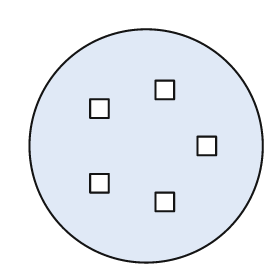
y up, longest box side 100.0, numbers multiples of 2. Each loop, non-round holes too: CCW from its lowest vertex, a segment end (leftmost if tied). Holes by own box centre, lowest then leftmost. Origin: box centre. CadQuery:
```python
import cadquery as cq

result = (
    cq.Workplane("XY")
    .moveTo(0.0, 0.0)
    .circle(50.0)
    .moveTo(4.0, -28.0)
    .lineTo(12.0, -28.0)
    .lineTo(12.0, -20.0)
    .lineTo(4.0, -20.0)
    .close()
    .moveTo(-24.0, -20.0)
    .lineTo(-16.0, -20.0)
    .lineTo(-16.0, -12.0)
    .lineTo(-24.0, -12.0)
    .close()
    .moveTo(22.0, -4.0)
    .lineTo(30.0, -4.0)
    .lineTo(30.0, 4.0)
    .lineTo(22.0, 4.0)
    .close()
    .moveTo(-24.0, 12.0)
    .lineTo(-16.0, 12.0)
    .lineTo(-16.0, 20.0)
    .lineTo(-24.0, 20.0)
    .close()
    .moveTo(4.0, 20.0)
    .lineTo(12.0, 20.0)
    .lineTo(12.0, 28.0)
    .lineTo(4.0, 28.0)
    .close()
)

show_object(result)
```